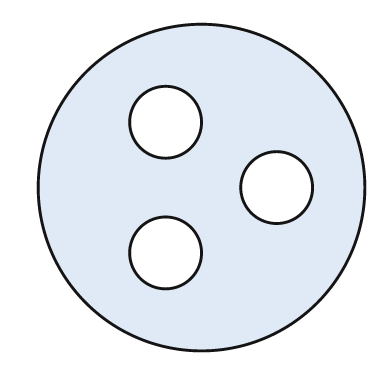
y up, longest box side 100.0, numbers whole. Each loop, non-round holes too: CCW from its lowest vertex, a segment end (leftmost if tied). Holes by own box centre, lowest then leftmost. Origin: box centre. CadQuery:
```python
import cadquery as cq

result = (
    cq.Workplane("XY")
    .moveTo(0.0, 0.0)
    .circle(50.0)
    .moveTo(-11.0, -20.0)
    .circle(11.0)
    .moveTo(23.0, 0.0)
    .circle(11.0)
    .moveTo(-11.0, 20.0)
    .circle(11.0)
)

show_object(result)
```